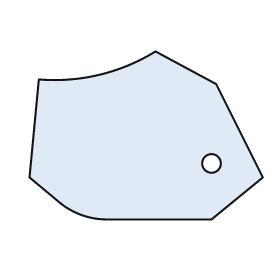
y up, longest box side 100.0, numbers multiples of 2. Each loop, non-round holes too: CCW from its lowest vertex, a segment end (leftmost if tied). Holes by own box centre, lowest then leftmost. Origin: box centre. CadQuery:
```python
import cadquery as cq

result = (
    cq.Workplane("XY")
    .moveTo(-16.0, -36.0)
    .lineTo(28.0, -36.0)
    .lineTo(50.0, -18.0)
    .lineTo(30.0, 22.0)
    .lineTo(4.0, 36.0)
    .threePointArc((-20.0, 26.0), (-46.0, 24.0))
    .lineTo(-50.0, -18.0)
    .lineTo(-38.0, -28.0)
    .threePointArc((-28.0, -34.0), (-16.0, -36.0))
    .close()
    .moveTo(28.0, -12.0)
    .circle(4.0)
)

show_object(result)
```